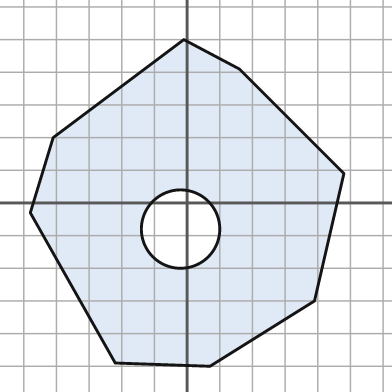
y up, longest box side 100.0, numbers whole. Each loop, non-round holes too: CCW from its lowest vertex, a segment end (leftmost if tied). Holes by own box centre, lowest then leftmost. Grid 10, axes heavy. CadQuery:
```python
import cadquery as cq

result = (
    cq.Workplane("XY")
    .moveTo(7.0, -50.0)
    .lineTo(39.0, -30.0)
    .lineTo(48.0, 9.0)
    .lineTo(16.0, 41.0)
    .lineTo(-1.0, 50.0)
    .lineTo(-41.0, 20.0)
    .lineTo(-48.0, -3.0)
    .lineTo(-22.0, -49.0)
    .close()
    .moveTo(-2.0, -8.0)
    .circle(12.0)
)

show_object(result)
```